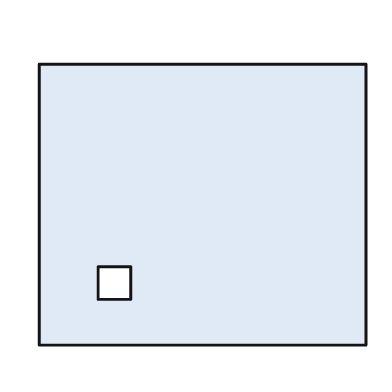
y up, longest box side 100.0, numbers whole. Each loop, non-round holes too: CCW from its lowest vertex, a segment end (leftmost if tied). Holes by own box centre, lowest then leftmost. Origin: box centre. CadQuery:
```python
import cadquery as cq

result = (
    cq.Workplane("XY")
    .moveTo(-50.0, -43.0)
    .lineTo(50.0, -43.0)
    .lineTo(50.0, 43.0)
    .lineTo(-50.0, 43.0)
    .close()
    .moveTo(-32.0, -29.0)
    .lineTo(-22.0, -29.0)
    .lineTo(-22.0, -19.0)
    .lineTo(-32.0, -19.0)
    .close()
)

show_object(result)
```